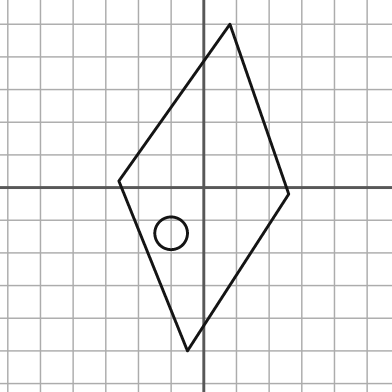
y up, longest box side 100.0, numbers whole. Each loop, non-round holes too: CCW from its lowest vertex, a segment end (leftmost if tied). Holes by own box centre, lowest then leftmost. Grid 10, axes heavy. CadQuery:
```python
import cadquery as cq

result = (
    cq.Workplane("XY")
    .moveTo(-5.0, -50.0)
    .lineTo(26.0, -2.0)
    .lineTo(8.0, 50.0)
    .lineTo(-26.0, 2.0)
    .close()
    .moveTo(-10.0, -14.0)
    .circle(5.0)
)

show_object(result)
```